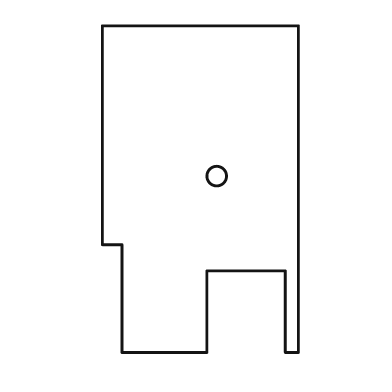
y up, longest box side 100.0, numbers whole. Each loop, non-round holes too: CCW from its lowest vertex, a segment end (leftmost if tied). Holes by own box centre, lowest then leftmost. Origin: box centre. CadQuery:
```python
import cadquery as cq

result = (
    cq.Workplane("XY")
    .moveTo(-24.0, -50.0)
    .lineTo(2.0, -50.0)
    .lineTo(2.0, -25.0)
    .lineTo(26.0, -25.0)
    .lineTo(26.0, -50.0)
    .lineTo(30.0, -50.0)
    .lineTo(30.0, 50.0)
    .lineTo(-30.0, 50.0)
    .lineTo(-30.0, -17.0)
    .lineTo(-24.0, -17.0)
    .close()
    .moveTo(5.0, 4.0)
    .circle(3.0)
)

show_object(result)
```